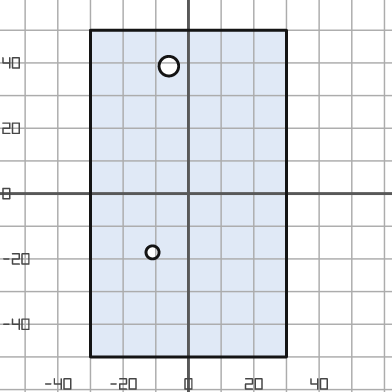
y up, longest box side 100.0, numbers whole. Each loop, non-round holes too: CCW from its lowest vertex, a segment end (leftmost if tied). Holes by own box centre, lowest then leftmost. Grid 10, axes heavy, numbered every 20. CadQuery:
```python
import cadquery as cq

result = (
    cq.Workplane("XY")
    .moveTo(-30.0, -50.0)
    .lineTo(30.0, -50.0)
    .lineTo(30.0, 50.0)
    .lineTo(-30.0, 50.0)
    .close()
    .moveTo(-11.0, -18.0)
    .circle(2.0)
    .moveTo(-6.0, 39.0)
    .circle(3.0)
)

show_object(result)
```